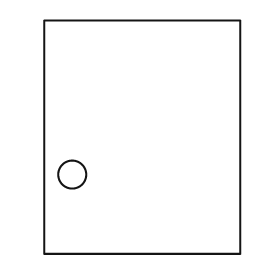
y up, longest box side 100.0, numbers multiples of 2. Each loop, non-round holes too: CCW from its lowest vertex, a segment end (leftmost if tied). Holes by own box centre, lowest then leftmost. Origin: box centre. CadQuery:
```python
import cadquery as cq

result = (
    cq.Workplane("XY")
    .moveTo(-42.0, -50.0)
    .lineTo(42.0, -50.0)
    .lineTo(42.0, 50.0)
    .lineTo(-42.0, 50.0)
    .close()
    .moveTo(-30.0, -16.0)
    .circle(6.0)
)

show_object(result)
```